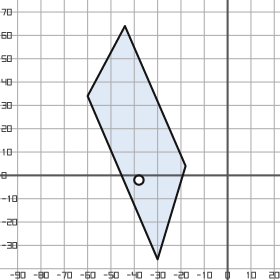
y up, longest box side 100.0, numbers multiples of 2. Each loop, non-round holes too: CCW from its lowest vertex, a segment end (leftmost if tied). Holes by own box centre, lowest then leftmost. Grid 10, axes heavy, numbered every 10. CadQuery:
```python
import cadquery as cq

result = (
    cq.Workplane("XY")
    .moveTo(-30.0, -36.0)
    .lineTo(-18.0, 4.0)
    .lineTo(-44.0, 64.0)
    .lineTo(-60.0, 34.0)
    .close()
    .moveTo(-38.0, -2.0)
    .circle(2.0)
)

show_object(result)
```